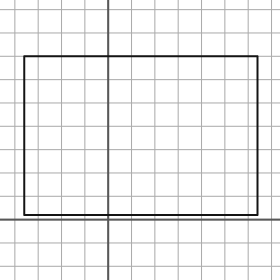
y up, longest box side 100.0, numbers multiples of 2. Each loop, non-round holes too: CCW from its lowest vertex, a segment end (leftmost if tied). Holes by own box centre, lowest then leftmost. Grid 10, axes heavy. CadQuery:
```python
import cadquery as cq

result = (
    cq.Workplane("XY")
    .moveTo(-36.0, 2.0)
    .lineTo(64.0, 2.0)
    .lineTo(64.0, 70.0)
    .lineTo(-36.0, 70.0)
    .close()
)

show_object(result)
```